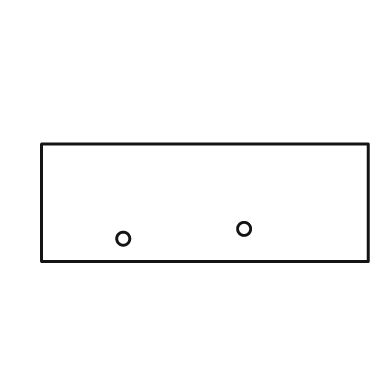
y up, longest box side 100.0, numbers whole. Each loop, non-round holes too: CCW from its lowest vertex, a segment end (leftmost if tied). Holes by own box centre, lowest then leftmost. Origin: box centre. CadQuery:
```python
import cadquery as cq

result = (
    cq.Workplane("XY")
    .moveTo(-50.0, -18.0)
    .lineTo(50.0, -18.0)
    .lineTo(50.0, 18.0)
    .lineTo(-50.0, 18.0)
    .close()
    .moveTo(-25.0, -11.0)
    .circle(2.0)
    .moveTo(12.0, -8.0)
    .circle(2.0)
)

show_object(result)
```